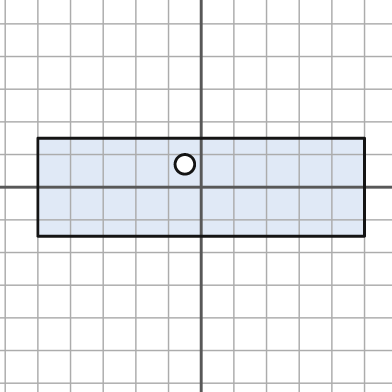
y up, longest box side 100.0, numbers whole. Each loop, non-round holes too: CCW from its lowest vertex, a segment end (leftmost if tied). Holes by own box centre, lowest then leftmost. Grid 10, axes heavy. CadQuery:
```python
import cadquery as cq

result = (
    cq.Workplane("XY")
    .moveTo(-50.0, -15.0)
    .lineTo(50.0, -15.0)
    .lineTo(50.0, 15.0)
    .lineTo(-50.0, 15.0)
    .close()
    .moveTo(-5.0, 7.0)
    .circle(3.0)
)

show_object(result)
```